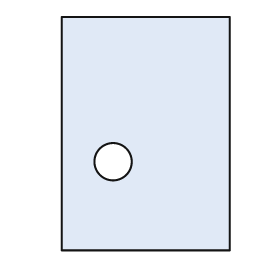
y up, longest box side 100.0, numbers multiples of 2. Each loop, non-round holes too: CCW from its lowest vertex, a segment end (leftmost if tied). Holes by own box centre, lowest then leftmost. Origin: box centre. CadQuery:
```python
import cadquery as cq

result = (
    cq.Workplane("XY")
    .moveTo(-36.0, -50.0)
    .lineTo(36.0, -50.0)
    .lineTo(36.0, 50.0)
    .lineTo(-36.0, 50.0)
    .close()
    .moveTo(-14.0, -12.0)
    .circle(8.0)
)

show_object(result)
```